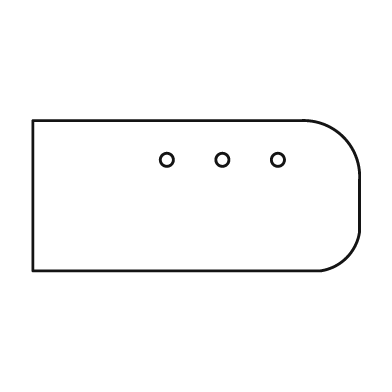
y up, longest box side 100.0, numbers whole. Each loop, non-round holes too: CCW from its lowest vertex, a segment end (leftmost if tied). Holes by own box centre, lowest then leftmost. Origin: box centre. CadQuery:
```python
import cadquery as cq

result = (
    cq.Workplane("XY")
    .moveTo(-50.0, -23.0)
    .lineTo(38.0, -23.0)
    .threePointArc((46.0, -19.0), (50.0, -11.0))
    .lineTo(50.0, 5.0)
    .threePointArc((45.0, 18.0), (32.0, 23.0))
    .lineTo(-50.0, 23.0)
    .close()
    .moveTo(-9.0, 11.0)
    .circle(2.0)
    .moveTo(8.0, 11.0)
    .circle(2.0)
    .moveTo(25.0, 11.0)
    .circle(2.0)
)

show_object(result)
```